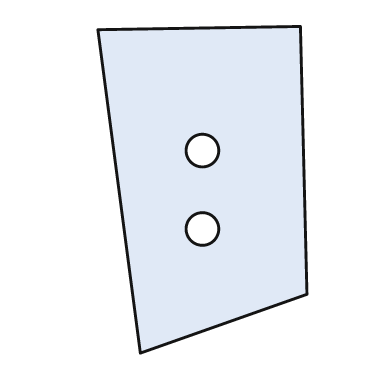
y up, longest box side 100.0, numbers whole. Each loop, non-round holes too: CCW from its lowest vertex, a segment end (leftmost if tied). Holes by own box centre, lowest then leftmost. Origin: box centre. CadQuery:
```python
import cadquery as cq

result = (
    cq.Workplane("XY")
    .moveTo(-19.0, -50.0)
    .lineTo(32.0, -32.0)
    .lineTo(30.0, 50.0)
    .lineTo(-32.0, 49.0)
    .close()
    .moveTo(0.0, -12.0)
    .circle(5.0)
    .moveTo(0.0, 12.0)
    .circle(5.0)
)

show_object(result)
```